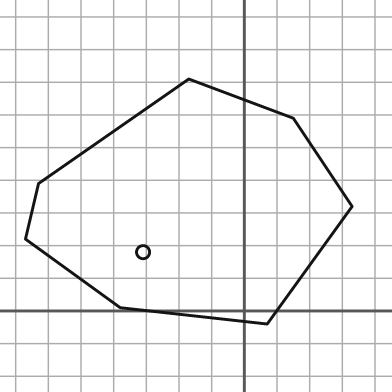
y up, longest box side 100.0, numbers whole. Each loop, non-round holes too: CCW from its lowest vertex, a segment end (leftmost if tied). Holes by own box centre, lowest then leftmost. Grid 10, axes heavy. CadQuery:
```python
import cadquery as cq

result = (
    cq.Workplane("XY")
    .moveTo(7.0, -4.0)
    .lineTo(33.0, 32.0)
    .lineTo(15.0, 59.0)
    .lineTo(-17.0, 71.0)
    .lineTo(-63.0, 39.0)
    .lineTo(-67.0, 22.0)
    .lineTo(-38.0, 1.0)
    .close()
    .moveTo(-31.0, 18.0)
    .circle(2.0)
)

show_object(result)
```